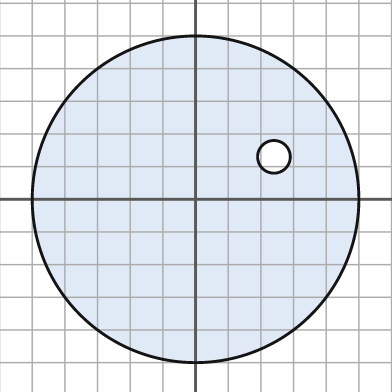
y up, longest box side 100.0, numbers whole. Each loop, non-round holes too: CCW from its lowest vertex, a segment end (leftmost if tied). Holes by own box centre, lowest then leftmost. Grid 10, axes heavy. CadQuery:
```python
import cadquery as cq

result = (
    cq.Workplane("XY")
    .moveTo(0.0, 0.0)
    .circle(50.0)
    .moveTo(24.0, 13.0)
    .circle(5.0)
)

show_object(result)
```